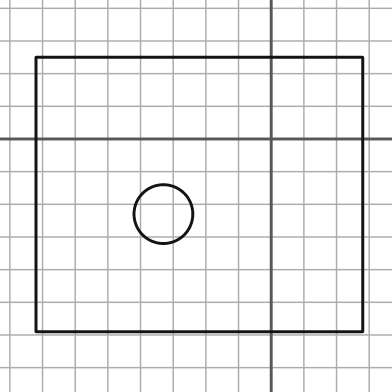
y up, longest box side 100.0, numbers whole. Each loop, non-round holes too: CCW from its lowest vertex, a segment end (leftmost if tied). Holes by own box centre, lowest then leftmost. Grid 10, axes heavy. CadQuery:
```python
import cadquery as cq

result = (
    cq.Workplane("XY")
    .moveTo(-72.0, -59.0)
    .lineTo(28.0, -59.0)
    .lineTo(28.0, 25.0)
    .lineTo(-72.0, 25.0)
    .close()
    .moveTo(-33.0, -23.0)
    .circle(9.0)
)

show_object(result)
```